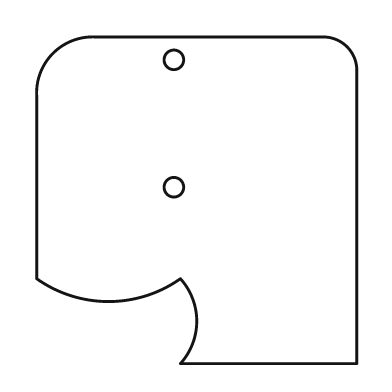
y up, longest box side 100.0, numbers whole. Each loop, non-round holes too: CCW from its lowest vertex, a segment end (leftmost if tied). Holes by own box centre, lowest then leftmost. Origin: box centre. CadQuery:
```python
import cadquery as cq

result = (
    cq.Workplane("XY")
    .moveTo(-5.0, -50.0)
    .lineTo(49.0, -50.0)
    .lineTo(49.0, 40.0)
    .threePointArc((46.0, 47.0), (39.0, 50.0))
    .lineTo(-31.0, 50.0)
    .threePointArc((-44.0, 45.0), (-49.0, 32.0))
    .lineTo(-49.0, -24.0)
    .threePointArc((-27.0, -31.0), (-5.0, -24.0))
    .threePointArc((0.0, -37.0), (-5.0, -50.0))
    .close()
    .moveTo(-7.0, 4.0)
    .circle(3.0)
    .moveTo(-7.0, 43.0)
    .circle(3.0)
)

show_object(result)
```